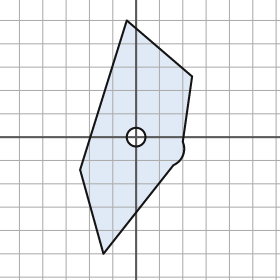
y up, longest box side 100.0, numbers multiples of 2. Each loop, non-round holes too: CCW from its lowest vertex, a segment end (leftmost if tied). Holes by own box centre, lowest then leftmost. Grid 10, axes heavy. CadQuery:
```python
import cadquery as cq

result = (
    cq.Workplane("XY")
    .moveTo(-14.0, -50.0)
    .lineTo(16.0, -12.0)
    .threePointArc((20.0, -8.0), (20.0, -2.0))
    .lineTo(24.0, 26.0)
    .lineTo(-4.0, 50.0)
    .lineTo(-24.0, -14.0)
    .close()
    .moveTo(0.0, 0.0)
    .circle(4.0)
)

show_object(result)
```